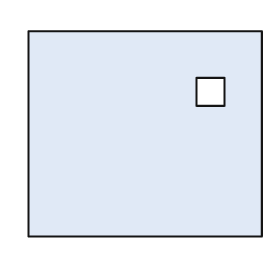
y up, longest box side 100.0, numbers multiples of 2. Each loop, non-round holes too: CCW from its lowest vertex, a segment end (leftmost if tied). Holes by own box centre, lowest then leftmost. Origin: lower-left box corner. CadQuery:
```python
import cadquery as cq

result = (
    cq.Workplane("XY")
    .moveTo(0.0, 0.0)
    .lineTo(100.0, 0.0)
    .lineTo(100.0, 88.0)
    .lineTo(0.0, 88.0)
    .close()
    .moveTo(72.0, 56.0)
    .lineTo(84.0, 56.0)
    .lineTo(84.0, 68.0)
    .lineTo(72.0, 68.0)
    .close()
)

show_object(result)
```